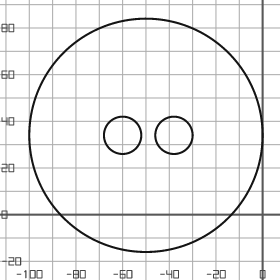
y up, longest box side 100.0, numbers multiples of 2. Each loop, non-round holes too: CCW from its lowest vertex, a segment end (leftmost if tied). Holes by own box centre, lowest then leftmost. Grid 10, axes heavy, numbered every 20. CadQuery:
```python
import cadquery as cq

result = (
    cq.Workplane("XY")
    .moveTo(-50.0, 34.0)
    .circle(50.0)
    .moveTo(-60.0, 34.0)
    .circle(8.0)
    .moveTo(-38.0, 34.0)
    .circle(8.0)
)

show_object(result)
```